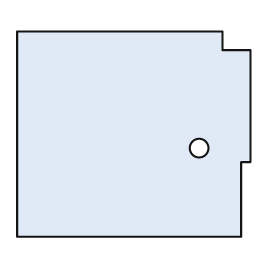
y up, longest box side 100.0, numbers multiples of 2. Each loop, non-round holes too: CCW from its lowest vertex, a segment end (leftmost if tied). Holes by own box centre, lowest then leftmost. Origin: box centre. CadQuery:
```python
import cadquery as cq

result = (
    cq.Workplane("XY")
    .moveTo(-50.0, -44.0)
    .lineTo(46.0, -44.0)
    .lineTo(46.0, -12.0)
    .lineTo(50.0, -12.0)
    .lineTo(50.0, 36.0)
    .lineTo(38.0, 36.0)
    .lineTo(38.0, 44.0)
    .lineTo(-50.0, 44.0)
    .close()
    .moveTo(28.0, -6.0)
    .circle(4.0)
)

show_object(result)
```